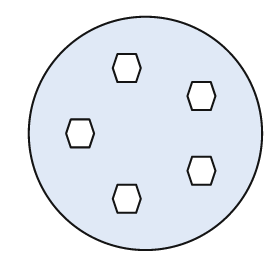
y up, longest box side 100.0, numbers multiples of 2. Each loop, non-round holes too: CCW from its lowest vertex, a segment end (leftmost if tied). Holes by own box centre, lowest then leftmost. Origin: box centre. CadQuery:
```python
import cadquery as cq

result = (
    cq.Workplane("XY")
    .moveTo(0.0, 0.0)
    .circle(50.0)
    .moveTo(-12.0, -34.0)
    .lineTo(-4.0, -34.0)
    .lineTo(-2.0, -28.0)
    .lineTo(-4.0, -22.0)
    .lineTo(-12.0, -22.0)
    .lineTo(-14.0, -28.0)
    .close()
    .moveTo(20.0, -22.0)
    .lineTo(28.0, -22.0)
    .lineTo(30.0, -16.0)
    .lineTo(28.0, -10.0)
    .lineTo(20.0, -10.0)
    .lineTo(18.0, -16.0)
    .close()
    .moveTo(-32.0, -6.0)
    .lineTo(-24.0, -6.0)
    .lineTo(-22.0, 0.0)
    .lineTo(-24.0, 6.0)
    .lineTo(-32.0, 6.0)
    .lineTo(-34.0, 0.0)
    .close()
    .moveTo(20.0, 10.0)
    .lineTo(28.0, 10.0)
    .lineTo(30.0, 16.0)
    .lineTo(28.0, 22.0)
    .lineTo(20.0, 22.0)
    .lineTo(18.0, 16.0)
    .close()
    .moveTo(-12.0, 22.0)
    .lineTo(-4.0, 22.0)
    .lineTo(-2.0, 28.0)
    .lineTo(-4.0, 34.0)
    .lineTo(-12.0, 34.0)
    .lineTo(-14.0, 28.0)
    .close()
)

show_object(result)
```